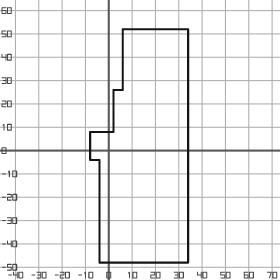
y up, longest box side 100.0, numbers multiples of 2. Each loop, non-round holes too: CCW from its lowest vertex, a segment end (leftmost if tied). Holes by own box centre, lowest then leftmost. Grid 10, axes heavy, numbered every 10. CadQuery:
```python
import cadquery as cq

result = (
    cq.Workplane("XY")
    .moveTo(-4.0, -48.0)
    .lineTo(34.0, -48.0)
    .lineTo(34.0, 52.0)
    .lineTo(6.0, 52.0)
    .lineTo(6.0, 26.0)
    .lineTo(2.0, 26.0)
    .lineTo(2.0, 8.0)
    .lineTo(-8.0, 8.0)
    .lineTo(-8.0, -4.0)
    .lineTo(-4.0, -4.0)
    .close()
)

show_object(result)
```